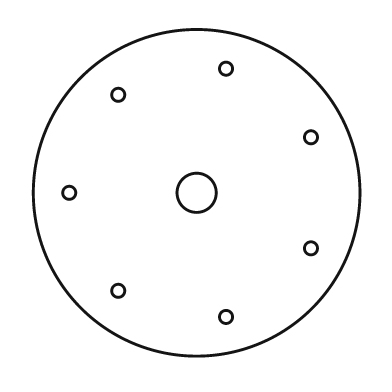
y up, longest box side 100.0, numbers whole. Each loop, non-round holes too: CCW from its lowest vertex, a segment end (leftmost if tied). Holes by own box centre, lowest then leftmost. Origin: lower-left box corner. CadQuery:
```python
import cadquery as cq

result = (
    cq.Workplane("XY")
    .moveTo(50.0, 50.0)
    .circle(50.0)
    .moveTo(59.0, 12.0)
    .circle(2.0)
    .moveTo(26.0, 20.0)
    .circle(2.0)
    .moveTo(85.0, 33.0)
    .circle(2.0)
    .moveTo(11.0, 50.0)
    .circle(2.0)
    .moveTo(50.0, 50.0)
    .circle(6.0)
    .moveTo(85.0, 67.0)
    .circle(2.0)
    .moveTo(26.0, 80.0)
    .circle(2.0)
    .moveTo(59.0, 88.0)
    .circle(2.0)
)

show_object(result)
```